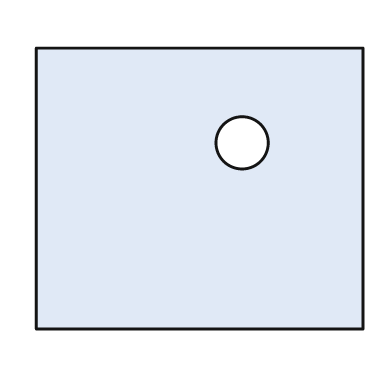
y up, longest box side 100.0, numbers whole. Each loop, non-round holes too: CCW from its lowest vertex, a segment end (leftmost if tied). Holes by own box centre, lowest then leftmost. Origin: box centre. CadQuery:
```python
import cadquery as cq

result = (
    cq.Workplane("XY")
    .moveTo(-50.0, -43.0)
    .lineTo(50.0, -43.0)
    .lineTo(50.0, 43.0)
    .lineTo(-50.0, 43.0)
    .close()
    .moveTo(13.0, 14.0)
    .circle(8.0)
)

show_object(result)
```